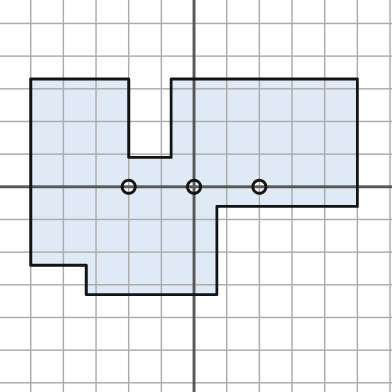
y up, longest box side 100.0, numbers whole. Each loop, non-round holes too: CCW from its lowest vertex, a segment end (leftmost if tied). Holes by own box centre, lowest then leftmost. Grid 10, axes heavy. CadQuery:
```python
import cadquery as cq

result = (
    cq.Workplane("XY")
    .moveTo(-33.0, -33.0)
    .lineTo(7.0, -33.0)
    .lineTo(7.0, -6.0)
    .lineTo(50.0, -6.0)
    .lineTo(50.0, 33.0)
    .lineTo(-7.0, 33.0)
    .lineTo(-7.0, 9.0)
    .lineTo(-20.0, 9.0)
    .lineTo(-20.0, 33.0)
    .lineTo(-50.0, 33.0)
    .lineTo(-50.0, -24.0)
    .lineTo(-33.0, -24.0)
    .close()
    .moveTo(-20.0, 0.0)
    .circle(2.0)
    .moveTo(0.0, 0.0)
    .circle(2.0)
    .moveTo(20.0, 0.0)
    .circle(2.0)
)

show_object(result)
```